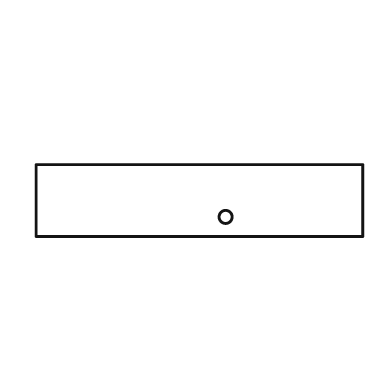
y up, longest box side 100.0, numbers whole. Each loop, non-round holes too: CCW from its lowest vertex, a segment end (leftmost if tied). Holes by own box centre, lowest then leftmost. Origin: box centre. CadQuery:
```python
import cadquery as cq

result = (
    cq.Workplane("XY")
    .moveTo(-50.0, -11.0)
    .lineTo(50.0, -11.0)
    .lineTo(50.0, 11.0)
    .lineTo(-50.0, 11.0)
    .close()
    .moveTo(8.0, -5.0)
    .circle(2.0)
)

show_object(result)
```